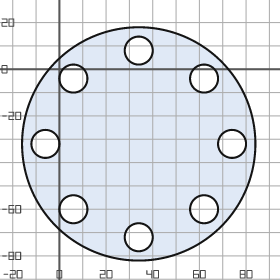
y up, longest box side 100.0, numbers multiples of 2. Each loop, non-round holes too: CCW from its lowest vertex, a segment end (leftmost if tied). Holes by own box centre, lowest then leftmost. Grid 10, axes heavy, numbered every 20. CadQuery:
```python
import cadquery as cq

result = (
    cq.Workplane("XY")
    .moveTo(34.0, -32.0)
    .circle(50.0)
    .moveTo(34.0, -72.0)
    .circle(6.0)
    .moveTo(6.0, -60.0)
    .circle(6.0)
    .moveTo(62.0, -60.0)
    .circle(6.0)
    .moveTo(-6.0, -32.0)
    .circle(6.0)
    .moveTo(74.0, -32.0)
    .circle(6.0)
    .moveTo(6.0, -4.0)
    .circle(6.0)
    .moveTo(62.0, -4.0)
    .circle(6.0)
    .moveTo(34.0, 8.0)
    .circle(6.0)
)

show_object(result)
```